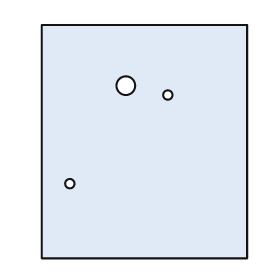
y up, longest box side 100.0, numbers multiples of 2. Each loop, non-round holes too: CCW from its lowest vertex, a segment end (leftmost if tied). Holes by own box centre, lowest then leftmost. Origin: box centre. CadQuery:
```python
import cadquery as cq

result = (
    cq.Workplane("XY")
    .moveTo(-44.0, -50.0)
    .lineTo(44.0, -50.0)
    .lineTo(44.0, 50.0)
    .lineTo(-44.0, 50.0)
    .close()
    .moveTo(-32.0, -18.0)
    .circle(2.0)
    .moveTo(10.0, 20.0)
    .circle(2.0)
    .moveTo(-8.0, 24.0)
    .circle(4.0)
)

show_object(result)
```